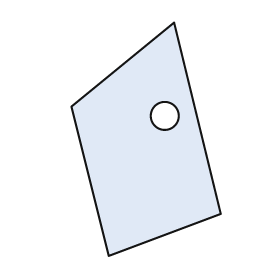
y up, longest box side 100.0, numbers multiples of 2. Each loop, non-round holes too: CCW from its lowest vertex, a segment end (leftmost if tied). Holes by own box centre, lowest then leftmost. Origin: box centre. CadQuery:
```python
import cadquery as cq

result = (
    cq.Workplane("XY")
    .moveTo(-16.0, -50.0)
    .lineTo(32.0, -32.0)
    .lineTo(12.0, 50.0)
    .lineTo(-32.0, 14.0)
    .close()
    .moveTo(8.0, 10.0)
    .circle(6.0)
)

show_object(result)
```